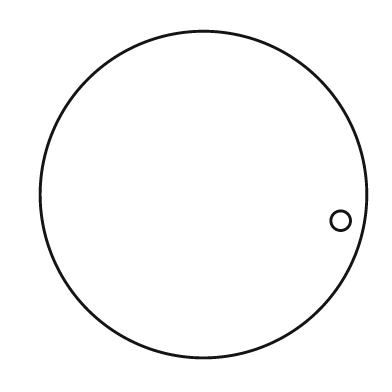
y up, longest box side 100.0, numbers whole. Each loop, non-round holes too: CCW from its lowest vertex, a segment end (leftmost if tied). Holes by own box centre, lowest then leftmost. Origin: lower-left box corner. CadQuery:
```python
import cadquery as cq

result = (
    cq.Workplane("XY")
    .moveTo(50.0, 50.0)
    .circle(50.0)
    .moveTo(92.0, 42.0)
    .circle(3.0)
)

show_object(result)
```